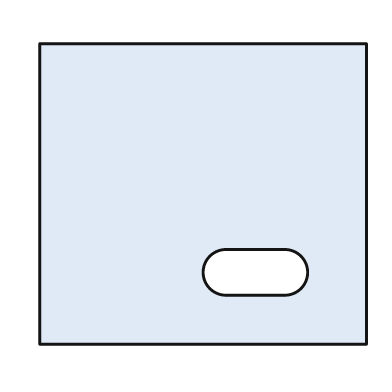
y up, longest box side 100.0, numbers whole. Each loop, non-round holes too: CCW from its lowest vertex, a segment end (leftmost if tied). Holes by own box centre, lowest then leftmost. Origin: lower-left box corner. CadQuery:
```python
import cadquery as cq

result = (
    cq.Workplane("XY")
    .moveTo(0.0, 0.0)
    .lineTo(100.0, 0.0)
    .lineTo(100.0, 92.0)
    .lineTo(0.0, 92.0)
    .close()
    .moveTo(57.0, 15.0)
    .lineTo(75.0, 15.0)
    .threePointArc((82.0, 22.0), (75.0, 29.0))
    .lineTo(57.0, 29.0)
    .threePointArc((50.0, 22.0), (57.0, 15.0))
    .close()
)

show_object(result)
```